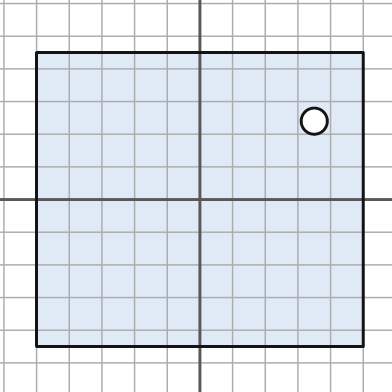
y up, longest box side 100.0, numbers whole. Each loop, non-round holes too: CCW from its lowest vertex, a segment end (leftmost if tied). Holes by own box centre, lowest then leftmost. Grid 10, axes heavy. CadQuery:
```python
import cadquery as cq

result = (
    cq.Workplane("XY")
    .moveTo(-50.0, -45.0)
    .lineTo(50.0, -45.0)
    .lineTo(50.0, 45.0)
    .lineTo(-50.0, 45.0)
    .close()
    .moveTo(35.0, 24.0)
    .circle(4.0)
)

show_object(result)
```